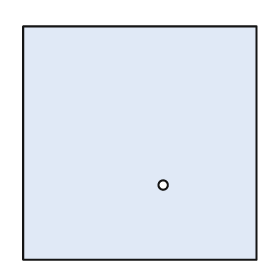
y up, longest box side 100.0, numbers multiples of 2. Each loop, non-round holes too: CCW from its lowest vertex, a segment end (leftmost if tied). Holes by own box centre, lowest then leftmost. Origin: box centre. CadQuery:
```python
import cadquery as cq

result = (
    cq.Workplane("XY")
    .moveTo(-50.0, -50.0)
    .lineTo(50.0, -50.0)
    .lineTo(50.0, 50.0)
    .lineTo(-50.0, 50.0)
    .close()
    .moveTo(10.0, -18.0)
    .circle(2.0)
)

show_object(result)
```